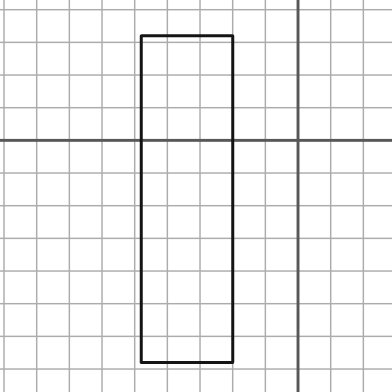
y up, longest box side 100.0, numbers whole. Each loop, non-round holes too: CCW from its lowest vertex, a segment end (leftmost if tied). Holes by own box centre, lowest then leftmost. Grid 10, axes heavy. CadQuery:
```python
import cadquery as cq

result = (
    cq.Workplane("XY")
    .moveTo(-48.0, -68.0)
    .lineTo(-20.0, -68.0)
    .lineTo(-20.0, 32.0)
    .lineTo(-48.0, 32.0)
    .close()
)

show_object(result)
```